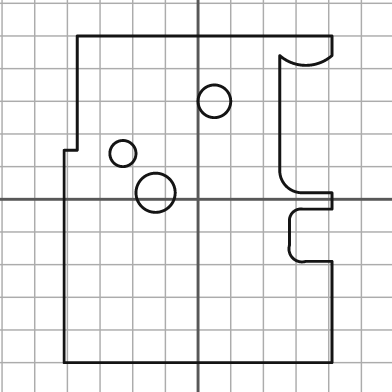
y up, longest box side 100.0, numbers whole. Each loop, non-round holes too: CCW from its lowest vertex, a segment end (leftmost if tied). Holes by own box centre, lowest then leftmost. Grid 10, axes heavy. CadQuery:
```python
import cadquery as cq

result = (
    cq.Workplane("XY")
    .moveTo(-41.0, -50.0)
    .lineTo(41.0, -50.0)
    .lineTo(41.0, -19.0)
    .lineTo(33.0, -19.0)
    .threePointArc((29.0, -18.0), (28.0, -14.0))
    .lineTo(28.0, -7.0)
    .threePointArc((29.0, -4.0), (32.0, -3.0))
    .lineTo(41.0, -3.0)
    .lineTo(41.0, 2.0)
    .lineTo(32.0, 2.0)
    .threePointArc((27.0, 4.0), (25.0, 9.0))
    .lineTo(25.0, 44.0)
    .threePointArc((33.0, 41.0), (41.0, 44.0))
    .lineTo(41.0, 50.0)
    .lineTo(-37.0, 50.0)
    .lineTo(-37.0, 15.0)
    .lineTo(-41.0, 15.0)
    .close()
    .moveTo(-13.0, 2.0)
    .circle(6.0)
    .moveTo(-23.0, 14.0)
    .circle(4.0)
    .moveTo(5.0, 30.0)
    .circle(5.0)
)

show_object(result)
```